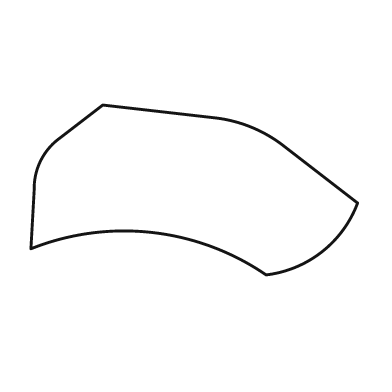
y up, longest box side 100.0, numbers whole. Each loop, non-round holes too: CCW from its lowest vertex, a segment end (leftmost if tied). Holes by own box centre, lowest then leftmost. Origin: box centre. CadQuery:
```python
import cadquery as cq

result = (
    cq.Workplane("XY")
    .moveTo(22.0, -26.0)
    .threePointArc((39.0, -19.0), (50.0, -4.0))
    .lineTo(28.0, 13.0)
    .threePointArc((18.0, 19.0), (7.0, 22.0))
    .lineTo(-28.0, 26.0)
    .lineTo(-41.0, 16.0)
    .threePointArc((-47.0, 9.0), (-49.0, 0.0))
    .lineTo(-50.0, -18.0)
    .threePointArc((-13.0, -13.0), (22.0, -26.0))
    .close()
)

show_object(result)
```